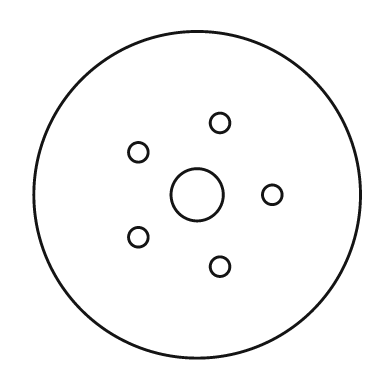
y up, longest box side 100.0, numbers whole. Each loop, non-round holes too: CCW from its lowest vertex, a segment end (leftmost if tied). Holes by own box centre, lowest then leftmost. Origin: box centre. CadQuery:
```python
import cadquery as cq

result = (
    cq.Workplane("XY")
    .moveTo(0.0, 0.0)
    .circle(50.0)
    .moveTo(7.0, -22.0)
    .circle(3.0)
    .moveTo(-18.0, -13.0)
    .circle(3.0)
    .moveTo(0.0, 0.0)
    .circle(8.0)
    .moveTo(23.0, 0.0)
    .circle(3.0)
    .moveTo(-18.0, 13.0)
    .circle(3.0)
    .moveTo(7.0, 22.0)
    .circle(3.0)
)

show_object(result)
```